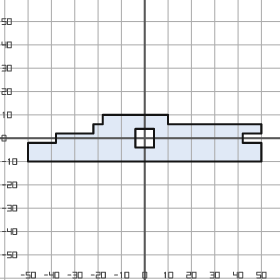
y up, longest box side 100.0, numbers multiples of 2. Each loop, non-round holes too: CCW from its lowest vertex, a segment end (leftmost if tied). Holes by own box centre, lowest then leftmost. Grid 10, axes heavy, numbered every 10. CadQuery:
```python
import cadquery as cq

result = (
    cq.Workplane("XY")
    .moveTo(-50.0, -10.0)
    .lineTo(50.0, -10.0)
    .lineTo(50.0, -2.0)
    .lineTo(42.0, -2.0)
    .lineTo(42.0, 2.0)
    .lineTo(50.0, 2.0)
    .lineTo(50.0, 6.0)
    .lineTo(10.0, 6.0)
    .lineTo(10.0, 10.0)
    .lineTo(-18.0, 10.0)
    .lineTo(-18.0, 6.0)
    .lineTo(-22.0, 6.0)
    .lineTo(-22.0, 2.0)
    .lineTo(-38.0, 2.0)
    .lineTo(-38.0, -2.0)
    .lineTo(-50.0, -2.0)
    .close()
    .moveTo(-4.0, -4.0)
    .lineTo(4.0, -4.0)
    .lineTo(4.0, 4.0)
    .lineTo(-4.0, 4.0)
    .close()
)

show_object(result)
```